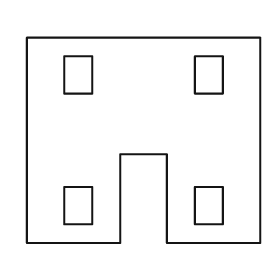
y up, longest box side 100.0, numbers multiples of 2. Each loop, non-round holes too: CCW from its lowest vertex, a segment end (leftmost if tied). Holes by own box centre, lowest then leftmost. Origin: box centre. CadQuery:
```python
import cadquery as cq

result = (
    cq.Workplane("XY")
    .moveTo(-50.0, -44.0)
    .lineTo(-10.0, -44.0)
    .lineTo(-10.0, -6.0)
    .lineTo(10.0, -6.0)
    .lineTo(10.0, -44.0)
    .lineTo(50.0, -44.0)
    .lineTo(50.0, 44.0)
    .lineTo(-50.0, 44.0)
    .close()
    .moveTo(-34.0, -36.0)
    .lineTo(-22.0, -36.0)
    .lineTo(-22.0, -20.0)
    .lineTo(-34.0, -20.0)
    .close()
    .moveTo(22.0, -36.0)
    .lineTo(34.0, -36.0)
    .lineTo(34.0, -20.0)
    .lineTo(22.0, -20.0)
    .close()
    .moveTo(-34.0, 20.0)
    .lineTo(-22.0, 20.0)
    .lineTo(-22.0, 36.0)
    .lineTo(-34.0, 36.0)
    .close()
    .moveTo(22.0, 20.0)
    .lineTo(34.0, 20.0)
    .lineTo(34.0, 36.0)
    .lineTo(22.0, 36.0)
    .close()
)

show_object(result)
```